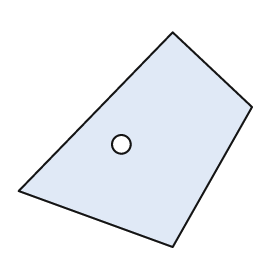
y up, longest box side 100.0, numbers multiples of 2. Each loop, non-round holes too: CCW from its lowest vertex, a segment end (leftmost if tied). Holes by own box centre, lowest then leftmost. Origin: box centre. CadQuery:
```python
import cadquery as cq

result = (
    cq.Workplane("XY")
    .moveTo(16.0, -46.0)
    .lineTo(50.0, 14.0)
    .lineTo(16.0, 46.0)
    .lineTo(-50.0, -22.0)
    .close()
    .moveTo(-6.0, -2.0)
    .circle(4.0)
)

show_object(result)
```